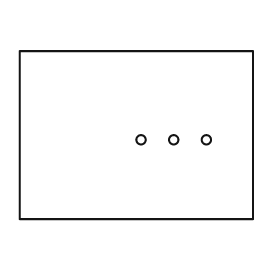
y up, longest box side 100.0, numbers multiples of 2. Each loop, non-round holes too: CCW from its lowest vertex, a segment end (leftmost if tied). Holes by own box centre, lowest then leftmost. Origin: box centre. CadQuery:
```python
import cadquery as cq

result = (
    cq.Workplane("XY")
    .moveTo(-50.0, -36.0)
    .lineTo(50.0, -36.0)
    .lineTo(50.0, 36.0)
    .lineTo(-50.0, 36.0)
    .close()
    .moveTo(2.0, -2.0)
    .circle(2.0)
    .moveTo(16.0, -2.0)
    .circle(2.0)
    .moveTo(30.0, -2.0)
    .circle(2.0)
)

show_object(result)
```